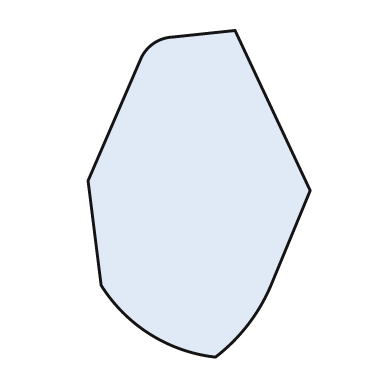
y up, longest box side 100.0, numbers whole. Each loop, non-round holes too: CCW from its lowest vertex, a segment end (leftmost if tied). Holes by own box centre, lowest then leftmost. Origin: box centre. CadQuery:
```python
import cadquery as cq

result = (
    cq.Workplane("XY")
    .moveTo(5.0, -50.0)
    .threePointArc((15.0, -40.0), (22.0, -28.0))
    .lineTo(34.0, 1.0)
    .lineTo(11.0, 50.0)
    .lineTo(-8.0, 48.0)
    .threePointArc((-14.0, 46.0), (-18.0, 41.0))
    .lineTo(-34.0, 4.0)
    .lineTo(-30.0, -28.0)
    .threePointArc((-15.0, -43.0), (5.0, -50.0))
    .close()
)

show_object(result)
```